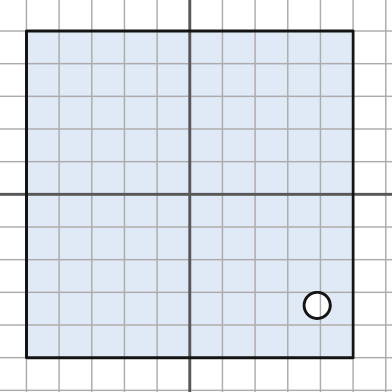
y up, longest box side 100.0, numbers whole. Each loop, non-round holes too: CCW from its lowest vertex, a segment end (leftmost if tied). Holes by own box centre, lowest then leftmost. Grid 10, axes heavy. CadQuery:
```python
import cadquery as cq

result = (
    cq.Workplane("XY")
    .moveTo(-50.0, -50.0)
    .lineTo(50.0, -50.0)
    .lineTo(50.0, 50.0)
    .lineTo(-50.0, 50.0)
    .close()
    .moveTo(39.0, -34.0)
    .circle(4.0)
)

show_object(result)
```